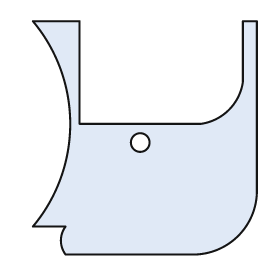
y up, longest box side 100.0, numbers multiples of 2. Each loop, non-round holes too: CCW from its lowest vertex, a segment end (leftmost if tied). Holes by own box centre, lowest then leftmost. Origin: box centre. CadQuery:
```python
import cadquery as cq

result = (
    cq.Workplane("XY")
    .moveTo(-34.0, -50.0)
    .lineTo(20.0, -50.0)
    .threePointArc((40.0, -42.0), (48.0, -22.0))
    .lineTo(48.0, 50.0)
    .lineTo(42.0, 50.0)
    .lineTo(42.0, 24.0)
    .threePointArc((36.0, 12.0), (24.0, 6.0))
    .lineTo(-28.0, 6.0)
    .lineTo(-28.0, 50.0)
    .lineTo(-48.0, 50.0)
    .threePointArc((-32.0, 6.0), (-48.0, -38.0))
    .lineTo(-34.0, -38.0)
    .threePointArc((-36.0, -44.0), (-34.0, -50.0))
    .close()
    .moveTo(-2.0, -2.0)
    .circle(4.0)
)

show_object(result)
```